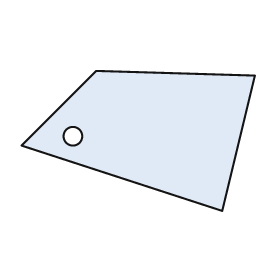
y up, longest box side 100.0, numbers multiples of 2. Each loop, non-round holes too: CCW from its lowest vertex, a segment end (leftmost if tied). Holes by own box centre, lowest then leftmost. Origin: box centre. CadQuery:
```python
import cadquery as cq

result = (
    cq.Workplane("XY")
    .moveTo(36.0, -30.0)
    .lineTo(50.0, 28.0)
    .lineTo(-18.0, 30.0)
    .lineTo(-50.0, -2.0)
    .close()
    .moveTo(-28.0, 2.0)
    .circle(4.0)
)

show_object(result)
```